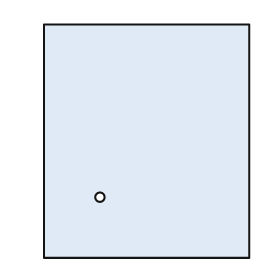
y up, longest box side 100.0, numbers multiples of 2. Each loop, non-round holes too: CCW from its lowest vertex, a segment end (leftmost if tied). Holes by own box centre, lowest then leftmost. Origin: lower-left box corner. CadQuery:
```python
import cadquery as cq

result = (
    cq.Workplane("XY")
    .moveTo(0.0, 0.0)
    .lineTo(88.0, 0.0)
    .lineTo(88.0, 100.0)
    .lineTo(0.0, 100.0)
    .close()
    .moveTo(24.0, 26.0)
    .circle(2.0)
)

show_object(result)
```